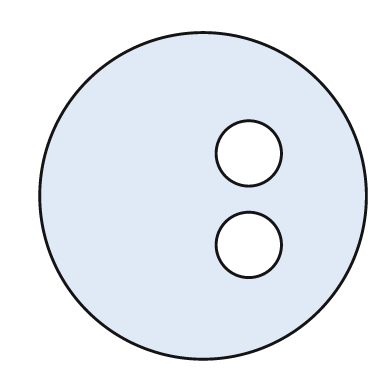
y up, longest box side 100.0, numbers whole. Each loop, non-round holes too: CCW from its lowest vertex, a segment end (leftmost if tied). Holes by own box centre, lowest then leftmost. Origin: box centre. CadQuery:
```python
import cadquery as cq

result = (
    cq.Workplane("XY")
    .moveTo(0.0, 0.0)
    .circle(50.0)
    .moveTo(14.0, -15.0)
    .circle(10.0)
    .moveTo(14.0, 13.0)
    .circle(10.0)
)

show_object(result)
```